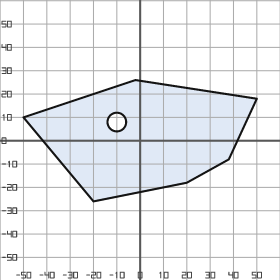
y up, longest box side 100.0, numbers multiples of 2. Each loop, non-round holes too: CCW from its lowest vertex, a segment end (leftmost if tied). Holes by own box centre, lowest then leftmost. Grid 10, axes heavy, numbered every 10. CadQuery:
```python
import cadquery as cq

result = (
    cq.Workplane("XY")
    .moveTo(-20.0, -26.0)
    .lineTo(20.0, -18.0)
    .lineTo(38.0, -8.0)
    .lineTo(50.0, 18.0)
    .lineTo(-2.0, 26.0)
    .lineTo(-50.0, 10.0)
    .close()
    .moveTo(-10.0, 8.0)
    .circle(4.0)
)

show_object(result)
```